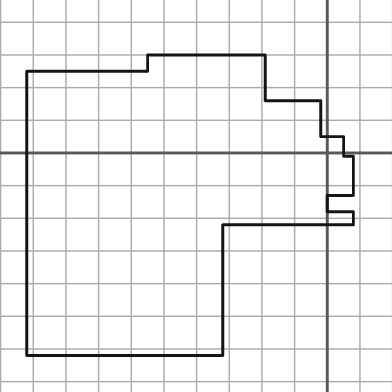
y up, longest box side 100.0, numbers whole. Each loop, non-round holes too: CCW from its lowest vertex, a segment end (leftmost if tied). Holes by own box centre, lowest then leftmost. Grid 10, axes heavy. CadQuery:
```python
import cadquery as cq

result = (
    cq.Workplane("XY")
    .moveTo(-92.0, -62.0)
    .lineTo(-32.0, -62.0)
    .lineTo(-32.0, -22.0)
    .lineTo(8.0, -22.0)
    .lineTo(8.0, -18.0)
    .lineTo(0.0, -18.0)
    .lineTo(0.0, -13.0)
    .lineTo(8.0, -13.0)
    .lineTo(8.0, -1.0)
    .lineTo(5.0, -1.0)
    .lineTo(5.0, 5.0)
    .lineTo(-2.0, 5.0)
    .lineTo(-2.0, 16.0)
    .lineTo(-19.0, 16.0)
    .lineTo(-19.0, 30.0)
    .lineTo(-55.0, 30.0)
    .lineTo(-55.0, 25.0)
    .lineTo(-92.0, 25.0)
    .close()
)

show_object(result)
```